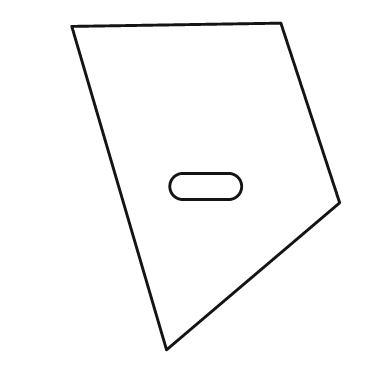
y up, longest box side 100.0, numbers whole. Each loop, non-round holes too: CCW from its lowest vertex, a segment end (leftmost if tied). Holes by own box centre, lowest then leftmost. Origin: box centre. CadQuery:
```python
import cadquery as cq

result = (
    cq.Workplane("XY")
    .moveTo(-12.0, -50.0)
    .lineTo(41.0, -5.0)
    .lineTo(23.0, 50.0)
    .lineTo(-41.0, 49.0)
    .close()
    .moveTo(-7.0, -4.0)
    .lineTo(7.0, -4.0)
    .threePointArc((11.0, 0.0), (7.0, 4.0))
    .lineTo(-7.0, 4.0)
    .threePointArc((-11.0, 0.0), (-7.0, -4.0))
    .close()
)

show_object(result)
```